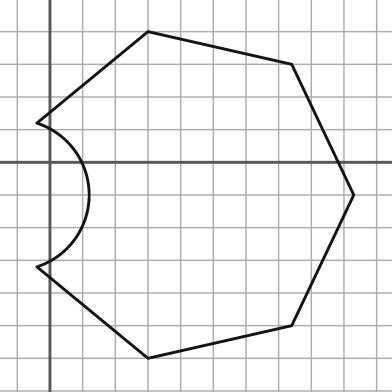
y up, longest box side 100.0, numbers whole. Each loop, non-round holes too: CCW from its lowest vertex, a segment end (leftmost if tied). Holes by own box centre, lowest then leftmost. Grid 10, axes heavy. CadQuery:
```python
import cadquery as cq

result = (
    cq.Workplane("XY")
    .moveTo(30.0, -60.0)
    .lineTo(74.0, -50.0)
    .lineTo(93.0, -10.0)
    .lineTo(74.0, 30.0)
    .lineTo(30.0, 40.0)
    .lineTo(-4.0, 12.0)
    .threePointArc((12.0, -10.0), (-4.0, -32.0))
    .close()
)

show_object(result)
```